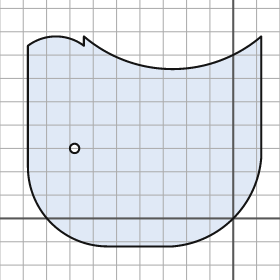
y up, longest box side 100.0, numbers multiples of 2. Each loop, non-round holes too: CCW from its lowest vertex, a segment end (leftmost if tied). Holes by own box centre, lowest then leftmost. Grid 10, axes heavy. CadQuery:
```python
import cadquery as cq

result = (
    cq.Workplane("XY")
    .moveTo(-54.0, -12.0)
    .lineTo(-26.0, -12.0)
    .threePointArc((0.0, 0.0), (12.0, 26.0))
    .lineTo(12.0, 78.0)
    .threePointArc((-26.0, 64.0), (-64.0, 78.0))
    .lineTo(-64.0, 74.0)
    .threePointArc((-76.0, 78.0), (-88.0, 74.0))
    .lineTo(-88.0, 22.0)
    .threePointArc((-78.0, -2.0), (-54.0, -12.0))
    .close()
    .moveTo(-68.0, 30.0)
    .circle(2.0)
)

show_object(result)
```